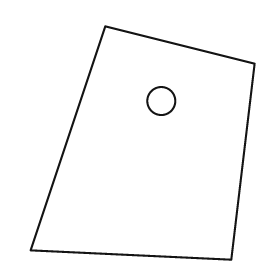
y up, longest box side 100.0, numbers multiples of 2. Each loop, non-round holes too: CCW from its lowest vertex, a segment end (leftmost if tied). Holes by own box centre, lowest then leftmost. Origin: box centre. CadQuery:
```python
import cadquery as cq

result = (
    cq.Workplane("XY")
    .moveTo(38.0, -50.0)
    .lineTo(48.0, 34.0)
    .lineTo(-16.0, 50.0)
    .lineTo(-48.0, -46.0)
    .close()
    .moveTo(8.0, 18.0)
    .circle(6.0)
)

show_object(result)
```